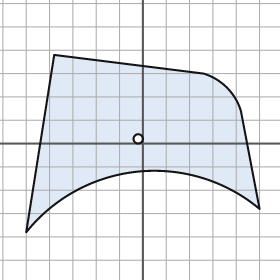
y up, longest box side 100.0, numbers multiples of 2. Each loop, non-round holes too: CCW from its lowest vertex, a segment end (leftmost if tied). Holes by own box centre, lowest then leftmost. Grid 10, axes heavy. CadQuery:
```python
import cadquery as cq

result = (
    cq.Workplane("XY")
    .moveTo(-50.0, -38.0)
    .threePointArc((-2.0, -12.0), (50.0, -28.0))
    .lineTo(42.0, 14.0)
    .threePointArc((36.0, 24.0), (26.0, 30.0))
    .lineTo(-38.0, 38.0)
    .close()
    .moveTo(-2.0, 2.0)
    .circle(2.0)
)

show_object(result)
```